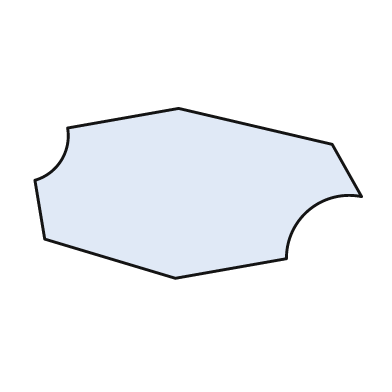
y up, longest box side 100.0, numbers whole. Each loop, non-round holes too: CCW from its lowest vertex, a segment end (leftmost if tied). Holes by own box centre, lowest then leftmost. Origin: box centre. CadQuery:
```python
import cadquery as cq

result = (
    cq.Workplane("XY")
    .moveTo(-7.0, -26.0)
    .lineTo(27.0, -20.0)
    .threePointArc((34.0, -5.0), (50.0, -1.0))
    .lineTo(41.0, 15.0)
    .lineTo(-6.0, 26.0)
    .lineTo(-40.0, 20.0)
    .threePointArc((-42.0, 10.0), (-50.0, 4.0))
    .lineTo(-47.0, -14.0)
    .close()
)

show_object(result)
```